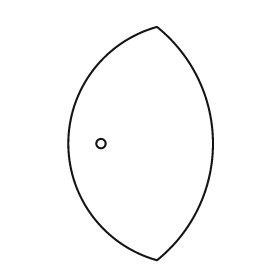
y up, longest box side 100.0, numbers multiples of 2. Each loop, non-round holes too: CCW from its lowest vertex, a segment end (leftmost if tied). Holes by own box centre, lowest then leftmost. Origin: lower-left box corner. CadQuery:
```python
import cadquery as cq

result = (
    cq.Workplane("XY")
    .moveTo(38.0, 0.0)
    .threePointArc((62.0, 50.0), (38.0, 100.0))
    .threePointArc((0.0, 50.0), (38.0, 0.0))
    .close()
    .moveTo(14.0, 50.0)
    .circle(2.0)
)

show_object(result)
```